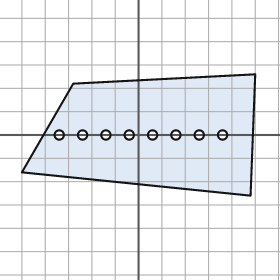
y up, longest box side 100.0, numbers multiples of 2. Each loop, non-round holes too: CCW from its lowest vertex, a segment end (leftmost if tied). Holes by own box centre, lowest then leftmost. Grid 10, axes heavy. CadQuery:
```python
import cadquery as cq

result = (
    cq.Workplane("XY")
    .moveTo(48.0, -26.0)
    .lineTo(50.0, 26.0)
    .lineTo(-28.0, 22.0)
    .lineTo(-50.0, -16.0)
    .close()
    .moveTo(-34.0, 0.0)
    .circle(2.0)
    .moveTo(-24.0, 0.0)
    .circle(2.0)
    .moveTo(-14.0, 0.0)
    .circle(2.0)
    .moveTo(-4.0, 0.0)
    .circle(2.0)
    .moveTo(6.0, 0.0)
    .circle(2.0)
    .moveTo(16.0, 0.0)
    .circle(2.0)
    .moveTo(26.0, 0.0)
    .circle(2.0)
    .moveTo(36.0, 0.0)
    .circle(2.0)
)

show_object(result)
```